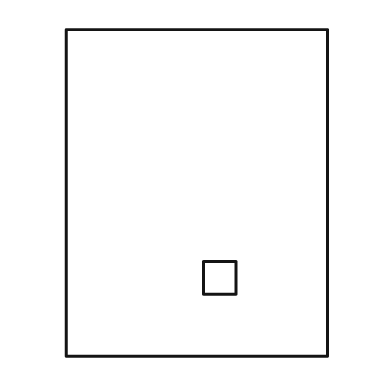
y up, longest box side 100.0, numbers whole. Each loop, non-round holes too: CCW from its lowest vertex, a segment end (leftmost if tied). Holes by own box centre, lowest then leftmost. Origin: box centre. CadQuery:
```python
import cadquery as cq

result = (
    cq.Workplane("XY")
    .moveTo(-40.0, -50.0)
    .lineTo(40.0, -50.0)
    .lineTo(40.0, 50.0)
    .lineTo(-40.0, 50.0)
    .close()
    .moveTo(2.0, -31.0)
    .lineTo(12.0, -31.0)
    .lineTo(12.0, -21.0)
    .lineTo(2.0, -21.0)
    .close()
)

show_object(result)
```